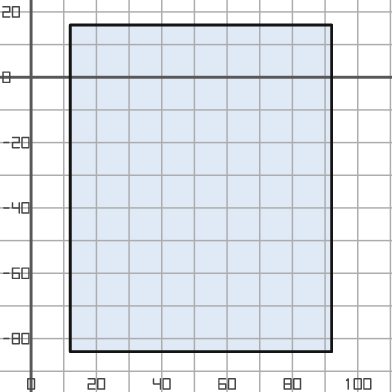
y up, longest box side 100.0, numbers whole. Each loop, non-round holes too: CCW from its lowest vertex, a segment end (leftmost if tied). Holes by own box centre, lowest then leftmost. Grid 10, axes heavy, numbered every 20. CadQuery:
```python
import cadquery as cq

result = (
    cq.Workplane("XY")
    .moveTo(12.0, -84.0)
    .lineTo(92.0, -84.0)
    .lineTo(92.0, 16.0)
    .lineTo(12.0, 16.0)
    .close()
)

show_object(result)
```